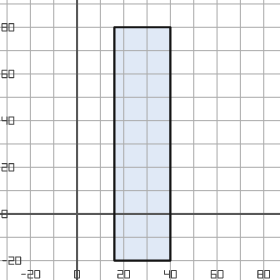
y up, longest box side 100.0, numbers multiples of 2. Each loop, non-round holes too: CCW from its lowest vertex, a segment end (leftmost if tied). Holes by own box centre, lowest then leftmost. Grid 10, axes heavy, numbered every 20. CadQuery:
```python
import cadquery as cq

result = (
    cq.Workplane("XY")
    .moveTo(16.0, -20.0)
    .lineTo(40.0, -20.0)
    .lineTo(40.0, 80.0)
    .lineTo(16.0, 80.0)
    .close()
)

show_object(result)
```